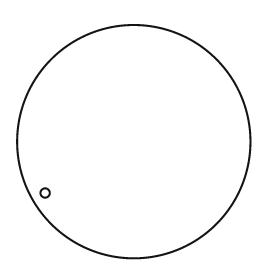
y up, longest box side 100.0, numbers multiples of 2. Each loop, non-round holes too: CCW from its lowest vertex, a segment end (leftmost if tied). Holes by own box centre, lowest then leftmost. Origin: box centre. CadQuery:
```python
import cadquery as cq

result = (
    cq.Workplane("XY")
    .moveTo(0.0, 0.0)
    .circle(50.0)
    .moveTo(-38.0, -22.0)
    .circle(2.0)
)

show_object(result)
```